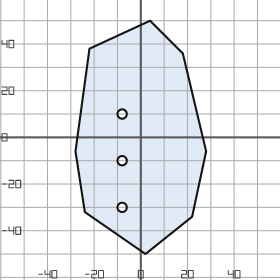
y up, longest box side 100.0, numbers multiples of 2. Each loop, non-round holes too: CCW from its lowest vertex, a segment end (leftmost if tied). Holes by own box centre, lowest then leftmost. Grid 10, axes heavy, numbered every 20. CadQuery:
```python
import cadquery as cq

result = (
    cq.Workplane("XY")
    .moveTo(2.0, -50.0)
    .lineTo(22.0, -34.0)
    .lineTo(28.0, -6.0)
    .lineTo(18.0, 36.0)
    .lineTo(4.0, 50.0)
    .lineTo(-22.0, 38.0)
    .lineTo(-28.0, -6.0)
    .lineTo(-24.0, -32.0)
    .close()
    .moveTo(-8.0, -30.0)
    .circle(2.0)
    .moveTo(-8.0, -10.0)
    .circle(2.0)
    .moveTo(-8.0, 10.0)
    .circle(2.0)
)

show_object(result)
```